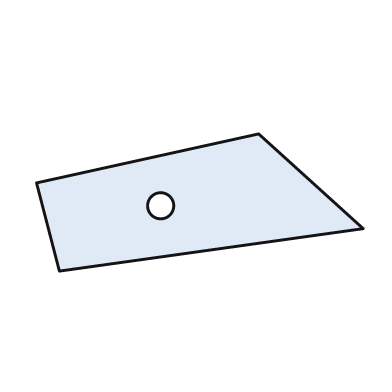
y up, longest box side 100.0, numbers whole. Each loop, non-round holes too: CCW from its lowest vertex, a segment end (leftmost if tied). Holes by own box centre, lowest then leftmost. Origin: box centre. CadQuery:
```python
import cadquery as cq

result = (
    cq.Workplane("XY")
    .moveTo(-43.0, -21.0)
    .lineTo(50.0, -8.0)
    .lineTo(18.0, 21.0)
    .lineTo(-50.0, 6.0)
    .close()
    .moveTo(-12.0, -1.0)
    .circle(4.0)
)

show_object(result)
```